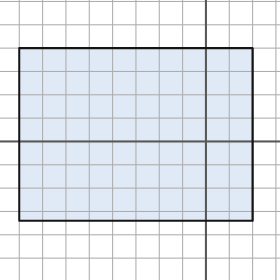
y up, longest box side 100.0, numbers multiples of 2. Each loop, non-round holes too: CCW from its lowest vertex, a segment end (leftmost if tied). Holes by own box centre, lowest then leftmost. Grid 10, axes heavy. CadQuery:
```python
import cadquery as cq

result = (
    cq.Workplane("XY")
    .moveTo(-80.0, -34.0)
    .lineTo(20.0, -34.0)
    .lineTo(20.0, 40.0)
    .lineTo(-80.0, 40.0)
    .close()
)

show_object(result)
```